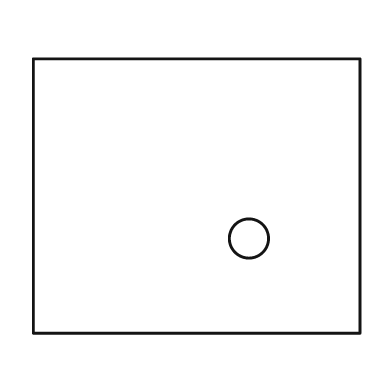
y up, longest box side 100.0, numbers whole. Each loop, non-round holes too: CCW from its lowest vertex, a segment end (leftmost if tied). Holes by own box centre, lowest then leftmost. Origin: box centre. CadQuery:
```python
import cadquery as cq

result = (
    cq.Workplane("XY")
    .moveTo(-50.0, -42.0)
    .lineTo(50.0, -42.0)
    .lineTo(50.0, 42.0)
    .lineTo(-50.0, 42.0)
    .close()
    .moveTo(16.0, -13.0)
    .circle(6.0)
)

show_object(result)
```